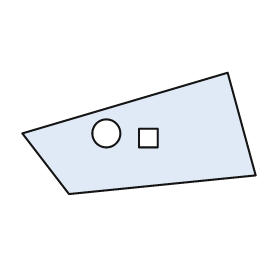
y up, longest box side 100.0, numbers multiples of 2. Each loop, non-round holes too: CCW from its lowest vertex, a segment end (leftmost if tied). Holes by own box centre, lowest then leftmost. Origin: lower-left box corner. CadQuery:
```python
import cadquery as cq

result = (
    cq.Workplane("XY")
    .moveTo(20.0, 0.0)
    .lineTo(100.0, 8.0)
    .lineTo(88.0, 52.0)
    .lineTo(0.0, 26.0)
    .close()
    .moveTo(50.0, 20.0)
    .lineTo(58.0, 20.0)
    .lineTo(58.0, 28.0)
    .lineTo(50.0, 28.0)
    .close()
    .moveTo(36.0, 26.0)
    .circle(6.0)
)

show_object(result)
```